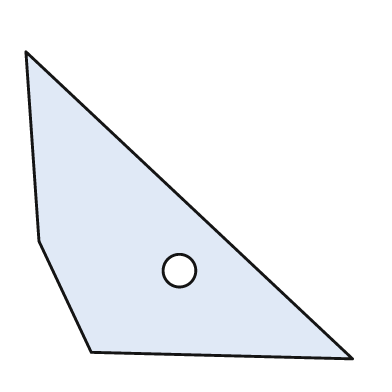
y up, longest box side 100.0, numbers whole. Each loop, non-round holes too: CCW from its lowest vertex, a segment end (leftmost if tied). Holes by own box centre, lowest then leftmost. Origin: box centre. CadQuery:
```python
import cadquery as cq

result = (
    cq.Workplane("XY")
    .moveTo(50.0, -47.0)
    .lineTo(-50.0, 47.0)
    .lineTo(-46.0, -11.0)
    .lineTo(-30.0, -45.0)
    .close()
    .moveTo(-3.0, -20.0)
    .circle(5.0)
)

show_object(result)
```